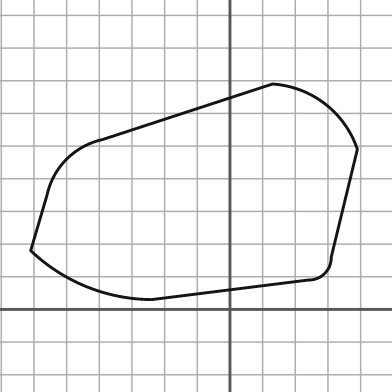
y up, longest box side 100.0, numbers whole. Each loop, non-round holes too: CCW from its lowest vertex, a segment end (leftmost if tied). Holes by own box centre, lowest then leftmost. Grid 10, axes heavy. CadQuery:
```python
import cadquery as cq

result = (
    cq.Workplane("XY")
    .moveTo(-24.0, 3.0)
    .lineTo(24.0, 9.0)
    .threePointArc((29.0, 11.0), (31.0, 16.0))
    .lineTo(39.0, 49.0)
    .threePointArc((29.0, 63.0), (13.0, 69.0))
    .lineTo(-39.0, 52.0)
    .threePointArc((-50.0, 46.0), (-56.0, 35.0))
    .lineTo(-61.0, 18.0)
    .threePointArc((-44.0, 7.0), (-24.0, 3.0))
    .close()
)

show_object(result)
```